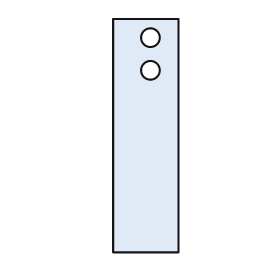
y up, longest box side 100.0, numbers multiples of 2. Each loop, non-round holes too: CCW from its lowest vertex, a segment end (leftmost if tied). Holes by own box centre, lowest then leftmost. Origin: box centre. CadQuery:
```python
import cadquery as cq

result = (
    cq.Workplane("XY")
    .moveTo(-14.0, -50.0)
    .lineTo(14.0, -50.0)
    .lineTo(14.0, 50.0)
    .lineTo(-14.0, 50.0)
    .close()
    .moveTo(2.0, 28.0)
    .circle(4.0)
    .moveTo(2.0, 42.0)
    .circle(4.0)
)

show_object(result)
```